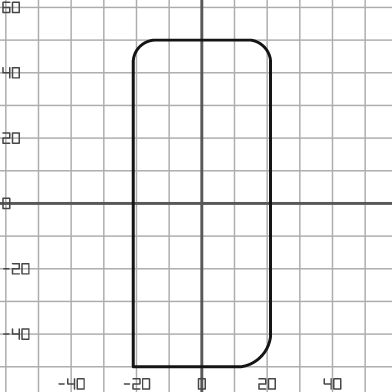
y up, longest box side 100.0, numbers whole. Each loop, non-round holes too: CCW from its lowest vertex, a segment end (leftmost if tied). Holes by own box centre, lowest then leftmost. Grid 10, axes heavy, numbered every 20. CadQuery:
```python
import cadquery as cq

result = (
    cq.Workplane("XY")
    .moveTo(-21.0, -50.0)
    .lineTo(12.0, -50.0)
    .threePointArc((18.0, -47.0), (21.0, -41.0))
    .lineTo(21.0, 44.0)
    .threePointArc((19.0, 48.0), (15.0, 50.0))
    .lineTo(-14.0, 50.0)
    .threePointArc((-19.0, 48.0), (-21.0, 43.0))
    .close()
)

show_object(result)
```